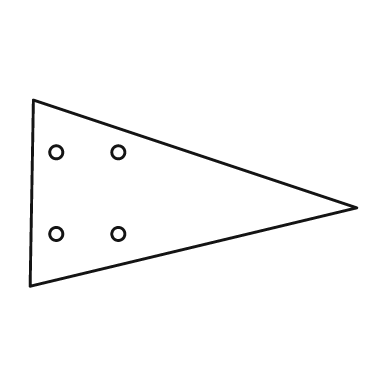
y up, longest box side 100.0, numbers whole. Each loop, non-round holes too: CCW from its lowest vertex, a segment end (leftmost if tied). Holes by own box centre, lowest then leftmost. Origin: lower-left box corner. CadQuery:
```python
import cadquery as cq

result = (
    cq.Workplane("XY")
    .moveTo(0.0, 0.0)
    .lineTo(100.0, 24.0)
    .lineTo(1.0, 57.0)
    .close()
    .moveTo(8.0, 16.0)
    .circle(2.0)
    .moveTo(27.0, 16.0)
    .circle(2.0)
    .moveTo(8.0, 41.0)
    .circle(2.0)
    .moveTo(27.0, 41.0)
    .circle(2.0)
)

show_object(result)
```